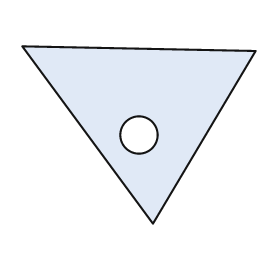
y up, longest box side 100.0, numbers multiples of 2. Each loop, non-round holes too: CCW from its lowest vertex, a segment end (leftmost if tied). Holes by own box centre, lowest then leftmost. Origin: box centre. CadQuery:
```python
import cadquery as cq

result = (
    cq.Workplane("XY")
    .moveTo(6.0, -38.0)
    .lineTo(50.0, 36.0)
    .lineTo(-50.0, 38.0)
    .close()
    .moveTo(0.0, 0.0)
    .circle(8.0)
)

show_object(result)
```